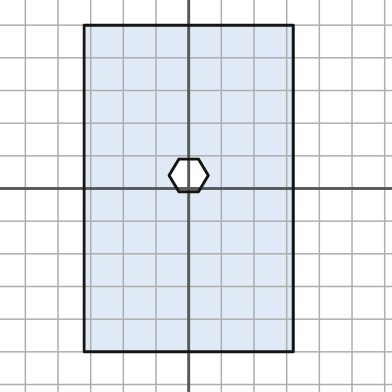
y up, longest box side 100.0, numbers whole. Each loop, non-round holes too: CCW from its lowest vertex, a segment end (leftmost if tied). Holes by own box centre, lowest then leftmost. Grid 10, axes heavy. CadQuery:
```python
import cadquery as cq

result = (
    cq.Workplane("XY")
    .moveTo(-32.0, -50.0)
    .lineTo(32.0, -50.0)
    .lineTo(32.0, 50.0)
    .lineTo(-32.0, 50.0)
    .close()
    .moveTo(-3.0, -1.0)
    .lineTo(3.0, -1.0)
    .lineTo(6.0, 4.0)
    .lineTo(3.0, 9.0)
    .lineTo(-3.0, 9.0)
    .lineTo(-6.0, 4.0)
    .close()
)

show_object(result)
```